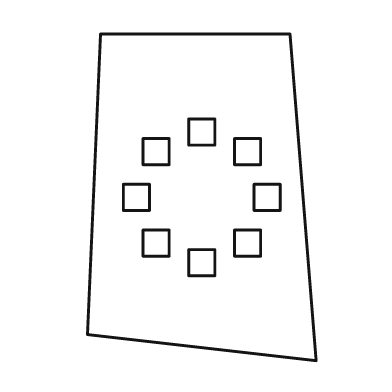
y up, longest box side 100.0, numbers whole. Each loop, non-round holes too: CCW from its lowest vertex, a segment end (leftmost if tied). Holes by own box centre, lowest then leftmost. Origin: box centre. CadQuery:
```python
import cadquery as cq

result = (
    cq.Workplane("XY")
    .moveTo(35.0, -50.0)
    .lineTo(27.0, 50.0)
    .lineTo(-31.0, 50.0)
    .lineTo(-35.0, -42.0)
    .close()
    .moveTo(-4.0, -24.0)
    .lineTo(4.0, -24.0)
    .lineTo(4.0, -16.0)
    .lineTo(-4.0, -16.0)
    .close()
    .moveTo(-18.0, -18.0)
    .lineTo(-10.0, -18.0)
    .lineTo(-10.0, -10.0)
    .lineTo(-18.0, -10.0)
    .close()
    .moveTo(10.0, -18.0)
    .lineTo(18.0, -18.0)
    .lineTo(18.0, -10.0)
    .lineTo(10.0, -10.0)
    .close()
    .moveTo(-24.0, -4.0)
    .lineTo(-16.0, -4.0)
    .lineTo(-16.0, 4.0)
    .lineTo(-24.0, 4.0)
    .close()
    .moveTo(16.0, -4.0)
    .lineTo(24.0, -4.0)
    .lineTo(24.0, 4.0)
    .lineTo(16.0, 4.0)
    .close()
    .moveTo(-18.0, 10.0)
    .lineTo(-10.0, 10.0)
    .lineTo(-10.0, 18.0)
    .lineTo(-18.0, 18.0)
    .close()
    .moveTo(10.0, 10.0)
    .lineTo(18.0, 10.0)
    .lineTo(18.0, 18.0)
    .lineTo(10.0, 18.0)
    .close()
    .moveTo(-4.0, 16.0)
    .lineTo(4.0, 16.0)
    .lineTo(4.0, 24.0)
    .lineTo(-4.0, 24.0)
    .close()
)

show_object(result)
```